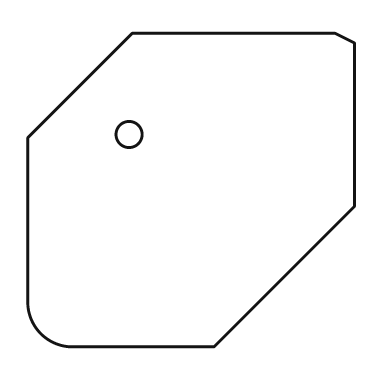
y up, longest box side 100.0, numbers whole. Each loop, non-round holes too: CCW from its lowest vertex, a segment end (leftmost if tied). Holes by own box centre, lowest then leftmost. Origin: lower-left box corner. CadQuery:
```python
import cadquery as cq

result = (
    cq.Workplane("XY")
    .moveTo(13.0, 0.0)
    .lineTo(57.0, 0.0)
    .lineTo(100.0, 43.0)
    .lineTo(100.0, 93.0)
    .lineTo(94.0, 96.0)
    .lineTo(32.0, 96.0)
    .lineTo(0.0, 64.0)
    .lineTo(0.0, 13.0)
    .threePointArc((4.0, 4.0), (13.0, 0.0))
    .close()
    .moveTo(31.0, 65.0)
    .circle(4.0)
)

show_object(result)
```